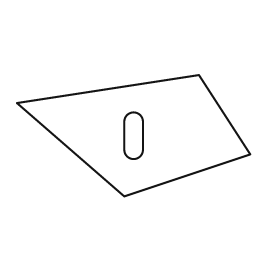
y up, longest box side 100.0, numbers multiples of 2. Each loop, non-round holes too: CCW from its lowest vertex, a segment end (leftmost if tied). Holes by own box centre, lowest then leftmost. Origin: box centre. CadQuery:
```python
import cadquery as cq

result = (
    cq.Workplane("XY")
    .moveTo(-4.0, -26.0)
    .lineTo(50.0, -8.0)
    .lineTo(28.0, 26.0)
    .lineTo(-50.0, 14.0)
    .close()
    .moveTo(-4.0, -6.0)
    .threePointArc((0.0, -10.0), (4.0, -6.0))
    .lineTo(4.0, 6.0)
    .threePointArc((0.0, 10.0), (-4.0, 6.0))
    .close()
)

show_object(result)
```